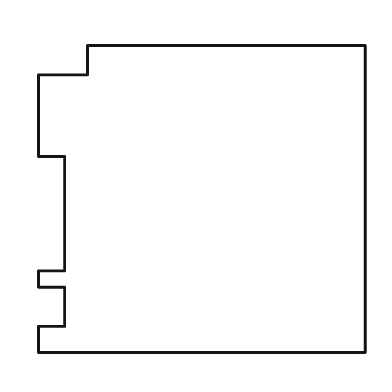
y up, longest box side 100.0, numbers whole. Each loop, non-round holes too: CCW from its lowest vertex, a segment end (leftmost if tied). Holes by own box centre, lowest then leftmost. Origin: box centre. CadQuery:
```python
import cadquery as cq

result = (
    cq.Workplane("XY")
    .moveTo(-50.0, -47.0)
    .lineTo(50.0, -47.0)
    .lineTo(50.0, 47.0)
    .lineTo(-35.0, 47.0)
    .lineTo(-35.0, 38.0)
    .lineTo(-50.0, 38.0)
    .lineTo(-50.0, 13.0)
    .lineTo(-42.0, 13.0)
    .lineTo(-42.0, -22.0)
    .lineTo(-50.0, -22.0)
    .lineTo(-50.0, -27.0)
    .lineTo(-42.0, -27.0)
    .lineTo(-42.0, -39.0)
    .lineTo(-50.0, -39.0)
    .close()
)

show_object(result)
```